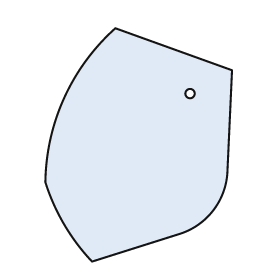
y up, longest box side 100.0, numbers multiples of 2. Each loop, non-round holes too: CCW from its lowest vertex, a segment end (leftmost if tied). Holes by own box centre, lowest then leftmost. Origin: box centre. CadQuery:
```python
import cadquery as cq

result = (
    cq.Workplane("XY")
    .moveTo(-20.0, -50.0)
    .lineTo(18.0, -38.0)
    .threePointArc((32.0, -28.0), (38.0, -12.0))
    .lineTo(40.0, 32.0)
    .lineTo(-10.0, 50.0)
    .threePointArc((-32.0, 20.0), (-40.0, -16.0))
    .threePointArc((-32.0, -34.0), (-20.0, -50.0))
    .close()
    .moveTo(22.0, 22.0)
    .circle(2.0)
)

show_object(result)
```